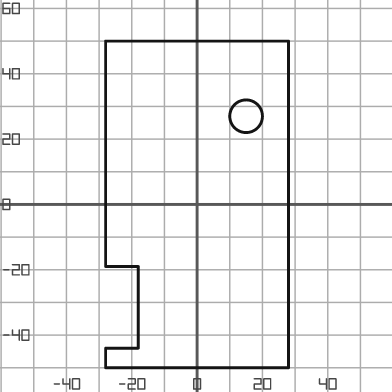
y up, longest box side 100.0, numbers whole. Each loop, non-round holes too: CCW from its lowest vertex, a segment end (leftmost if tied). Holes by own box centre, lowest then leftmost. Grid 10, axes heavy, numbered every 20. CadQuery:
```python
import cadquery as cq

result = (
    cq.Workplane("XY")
    .moveTo(-28.0, -50.0)
    .lineTo(28.0, -50.0)
    .lineTo(28.0, 50.0)
    .lineTo(-28.0, 50.0)
    .lineTo(-28.0, -19.0)
    .lineTo(-18.0, -19.0)
    .lineTo(-18.0, -44.0)
    .lineTo(-28.0, -44.0)
    .close()
    .moveTo(15.0, 27.0)
    .circle(5.0)
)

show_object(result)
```